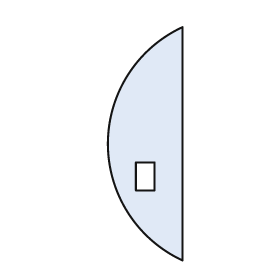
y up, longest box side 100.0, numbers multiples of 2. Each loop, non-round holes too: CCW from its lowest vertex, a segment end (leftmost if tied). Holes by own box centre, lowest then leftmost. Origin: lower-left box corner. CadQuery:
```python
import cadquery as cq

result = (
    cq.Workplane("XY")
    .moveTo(32.0, 0.0)
    .lineTo(32.0, 100.0)
    .threePointArc((0.0, 50.0), (32.0, 0.0))
    .close()
    .moveTo(12.0, 30.0)
    .lineTo(20.0, 30.0)
    .lineTo(20.0, 42.0)
    .lineTo(12.0, 42.0)
    .close()
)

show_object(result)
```